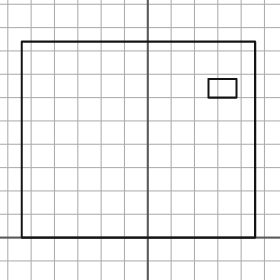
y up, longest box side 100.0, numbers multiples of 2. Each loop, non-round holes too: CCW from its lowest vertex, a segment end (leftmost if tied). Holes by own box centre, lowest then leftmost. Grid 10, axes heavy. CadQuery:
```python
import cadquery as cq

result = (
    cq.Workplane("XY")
    .moveTo(-54.0, 0.0)
    .lineTo(46.0, 0.0)
    .lineTo(46.0, 84.0)
    .lineTo(-54.0, 84.0)
    .close()
    .moveTo(26.0, 60.0)
    .lineTo(38.0, 60.0)
    .lineTo(38.0, 68.0)
    .lineTo(26.0, 68.0)
    .close()
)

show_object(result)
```